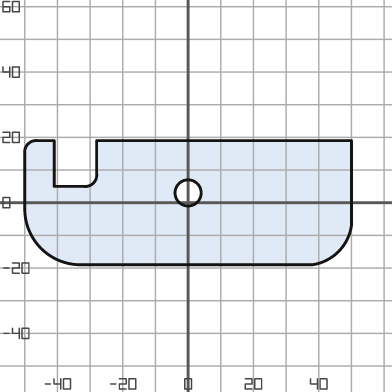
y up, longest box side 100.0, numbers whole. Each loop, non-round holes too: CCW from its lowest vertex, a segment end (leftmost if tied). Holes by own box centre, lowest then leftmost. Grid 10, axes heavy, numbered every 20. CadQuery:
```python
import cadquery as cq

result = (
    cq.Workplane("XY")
    .moveTo(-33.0, -19.0)
    .lineTo(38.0, -19.0)
    .threePointArc((46.0, -15.0), (50.0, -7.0))
    .lineTo(50.0, 19.0)
    .lineTo(-28.0, 19.0)
    .lineTo(-28.0, 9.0)
    .threePointArc((-29.0, 6.0), (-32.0, 5.0))
    .lineTo(-41.0, 5.0)
    .lineTo(-41.0, 19.0)
    .lineTo(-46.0, 19.0)
    .threePointArc((-49.0, 18.0), (-50.0, 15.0))
    .lineTo(-50.0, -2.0)
    .threePointArc((-45.0, -14.0), (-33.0, -19.0))
    .close()
    .moveTo(0.0, 3.0)
    .circle(4.0)
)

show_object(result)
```